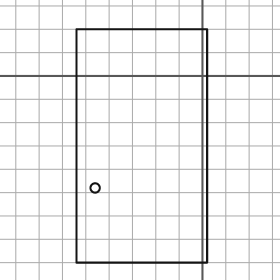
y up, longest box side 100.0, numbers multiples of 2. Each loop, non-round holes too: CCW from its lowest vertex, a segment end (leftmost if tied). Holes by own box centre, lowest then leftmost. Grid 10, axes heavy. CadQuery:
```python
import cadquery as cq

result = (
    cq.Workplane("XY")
    .moveTo(-54.0, -80.0)
    .lineTo(2.0, -80.0)
    .lineTo(2.0, 20.0)
    .lineTo(-54.0, 20.0)
    .close()
    .moveTo(-46.0, -48.0)
    .circle(2.0)
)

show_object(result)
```